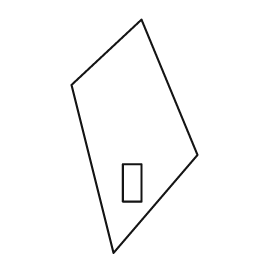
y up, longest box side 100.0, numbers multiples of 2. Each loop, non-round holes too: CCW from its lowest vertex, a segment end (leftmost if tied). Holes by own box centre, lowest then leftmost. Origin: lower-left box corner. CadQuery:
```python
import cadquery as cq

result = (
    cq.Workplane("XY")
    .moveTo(18.0, 0.0)
    .lineTo(54.0, 42.0)
    .lineTo(30.0, 100.0)
    .lineTo(0.0, 72.0)
    .close()
    .moveTo(22.0, 22.0)
    .lineTo(30.0, 22.0)
    .lineTo(30.0, 38.0)
    .lineTo(22.0, 38.0)
    .close()
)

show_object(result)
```